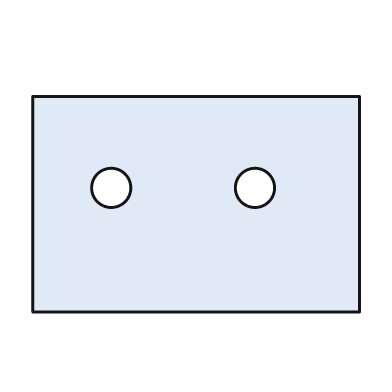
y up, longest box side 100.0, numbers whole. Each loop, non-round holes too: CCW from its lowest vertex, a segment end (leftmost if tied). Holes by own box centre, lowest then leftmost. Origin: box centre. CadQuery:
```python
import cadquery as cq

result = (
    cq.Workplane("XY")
    .moveTo(-50.0, -33.0)
    .lineTo(50.0, -33.0)
    .lineTo(50.0, 33.0)
    .lineTo(-50.0, 33.0)
    .close()
    .moveTo(-26.0, 5.0)
    .circle(6.0)
    .moveTo(18.0, 5.0)
    .circle(6.0)
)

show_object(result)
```